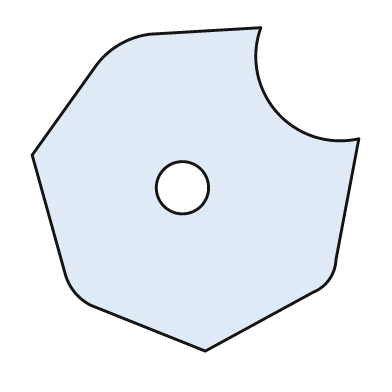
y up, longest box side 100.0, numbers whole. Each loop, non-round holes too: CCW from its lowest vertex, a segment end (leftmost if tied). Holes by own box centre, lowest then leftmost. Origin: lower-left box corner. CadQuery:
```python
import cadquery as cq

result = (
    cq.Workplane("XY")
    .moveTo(53.0, 0.0)
    .lineTo(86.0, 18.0)
    .threePointArc((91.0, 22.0), (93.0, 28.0))
    .lineTo(100.0, 65.0)
    .threePointArc((75.0, 73.0), (70.0, 99.0))
    .lineTo(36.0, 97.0)
    .threePointArc((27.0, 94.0), (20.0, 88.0))
    .lineTo(0.0, 60.0)
    .lineTo(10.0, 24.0)
    .threePointArc((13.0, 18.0), (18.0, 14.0))
    .close()
    .moveTo(46.0, 50.0)
    .circle(8.0)
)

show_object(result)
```